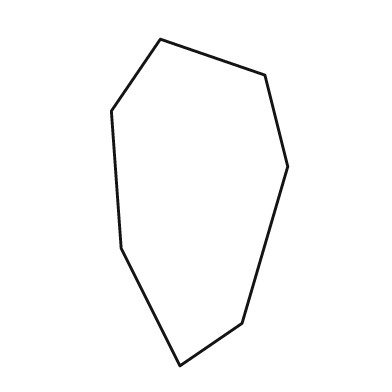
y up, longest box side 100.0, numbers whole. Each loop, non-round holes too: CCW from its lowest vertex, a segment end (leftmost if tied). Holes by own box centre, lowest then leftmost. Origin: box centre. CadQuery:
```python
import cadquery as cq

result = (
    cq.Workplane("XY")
    .moveTo(-6.0, -50.0)
    .lineTo(13.0, -37.0)
    .lineTo(27.0, 11.0)
    .lineTo(20.0, 39.0)
    .lineTo(-12.0, 50.0)
    .lineTo(-27.0, 28.0)
    .lineTo(-24.0, -14.0)
    .close()
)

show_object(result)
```